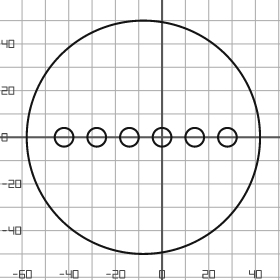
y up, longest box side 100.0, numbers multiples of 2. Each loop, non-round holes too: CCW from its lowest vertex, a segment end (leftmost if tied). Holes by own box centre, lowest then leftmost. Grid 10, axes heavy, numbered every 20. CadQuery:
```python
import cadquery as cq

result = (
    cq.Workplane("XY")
    .moveTo(-8.0, 0.0)
    .circle(50.0)
    .moveTo(-42.0, 0.0)
    .circle(4.0)
    .moveTo(-28.0, 0.0)
    .circle(4.0)
    .moveTo(-14.0, 0.0)
    .circle(4.0)
    .moveTo(0.0, 0.0)
    .circle(4.0)
    .moveTo(14.0, 0.0)
    .circle(4.0)
    .moveTo(28.0, 0.0)
    .circle(4.0)
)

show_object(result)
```